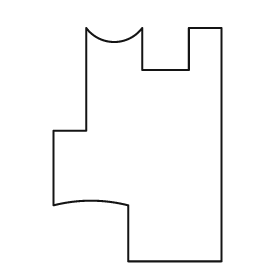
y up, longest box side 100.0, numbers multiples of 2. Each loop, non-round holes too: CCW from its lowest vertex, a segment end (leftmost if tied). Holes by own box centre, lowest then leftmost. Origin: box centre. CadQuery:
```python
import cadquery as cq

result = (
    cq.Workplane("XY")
    .moveTo(-4.0, -50.0)
    .lineTo(36.0, -50.0)
    .lineTo(36.0, 50.0)
    .lineTo(22.0, 50.0)
    .lineTo(22.0, 32.0)
    .lineTo(2.0, 32.0)
    .lineTo(2.0, 50.0)
    .threePointArc((-10.0, 44.0), (-22.0, 50.0))
    .lineTo(-22.0, 6.0)
    .lineTo(-36.0, 6.0)
    .lineTo(-36.0, -26.0)
    .threePointArc((-20.0, -24.0), (-4.0, -26.0))
    .close()
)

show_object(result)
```